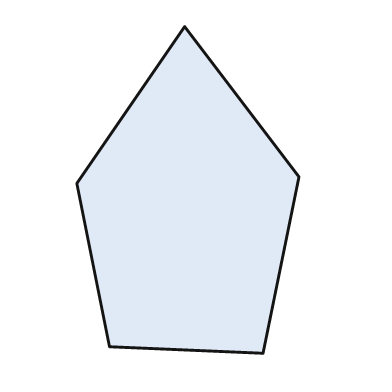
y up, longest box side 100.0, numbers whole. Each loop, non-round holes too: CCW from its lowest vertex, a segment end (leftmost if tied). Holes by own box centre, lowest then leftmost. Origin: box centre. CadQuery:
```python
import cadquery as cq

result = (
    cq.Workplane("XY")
    .moveTo(23.0, -50.0)
    .lineTo(34.0, 4.0)
    .lineTo(-1.0, 50.0)
    .lineTo(-34.0, 2.0)
    .lineTo(-24.0, -48.0)
    .close()
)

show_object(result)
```